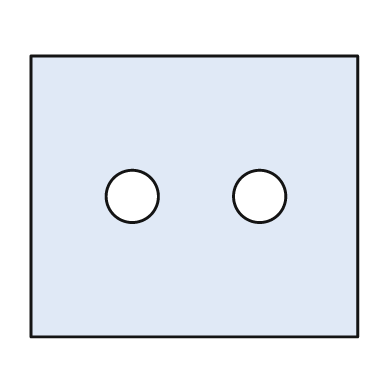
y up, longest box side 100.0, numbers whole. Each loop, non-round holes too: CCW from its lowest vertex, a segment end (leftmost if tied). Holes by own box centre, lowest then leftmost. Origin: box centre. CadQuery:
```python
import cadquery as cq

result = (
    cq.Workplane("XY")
    .moveTo(-50.0, -43.0)
    .lineTo(50.0, -43.0)
    .lineTo(50.0, 43.0)
    .lineTo(-50.0, 43.0)
    .close()
    .moveTo(-19.0, 0.0)
    .circle(8.0)
    .moveTo(20.0, 0.0)
    .circle(8.0)
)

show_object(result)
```